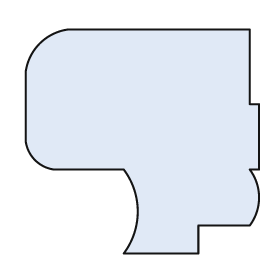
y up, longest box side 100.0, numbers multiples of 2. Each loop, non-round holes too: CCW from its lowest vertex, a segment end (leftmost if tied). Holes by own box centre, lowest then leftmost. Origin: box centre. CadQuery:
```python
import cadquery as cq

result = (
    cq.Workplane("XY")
    .moveTo(-8.0, -48.0)
    .lineTo(24.0, -48.0)
    .lineTo(24.0, -36.0)
    .lineTo(46.0, -36.0)
    .threePointArc((50.0, -24.0), (46.0, -12.0))
    .lineTo(50.0, -12.0)
    .lineTo(50.0, 16.0)
    .lineTo(46.0, 16.0)
    .lineTo(46.0, 48.0)
    .lineTo(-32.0, 48.0)
    .threePointArc((-44.0, 42.0), (-50.0, 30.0))
    .lineTo(-50.0, 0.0)
    .threePointArc((-46.0, -8.0), (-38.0, -12.0))
    .lineTo(-8.0, -12.0)
    .threePointArc((-2.0, -30.0), (-8.0, -48.0))
    .close()
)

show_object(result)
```